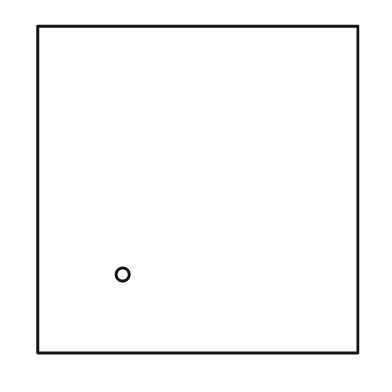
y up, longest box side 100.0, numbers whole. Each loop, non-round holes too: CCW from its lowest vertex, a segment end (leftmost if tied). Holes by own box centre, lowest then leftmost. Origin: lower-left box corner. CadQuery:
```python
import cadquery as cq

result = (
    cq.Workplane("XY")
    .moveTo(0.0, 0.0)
    .lineTo(98.0, 0.0)
    .lineTo(98.0, 100.0)
    .lineTo(0.0, 100.0)
    .close()
    .moveTo(26.0, 24.0)
    .circle(2.0)
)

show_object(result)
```